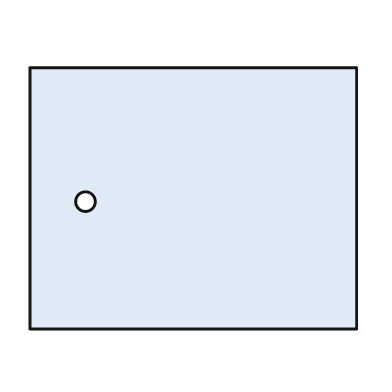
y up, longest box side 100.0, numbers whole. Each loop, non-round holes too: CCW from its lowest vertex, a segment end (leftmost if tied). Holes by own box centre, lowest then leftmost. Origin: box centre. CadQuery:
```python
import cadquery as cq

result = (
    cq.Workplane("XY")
    .moveTo(-50.0, -40.0)
    .lineTo(50.0, -40.0)
    .lineTo(50.0, 40.0)
    .lineTo(-50.0, 40.0)
    .close()
    .moveTo(-33.0, -1.0)
    .circle(3.0)
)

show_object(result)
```